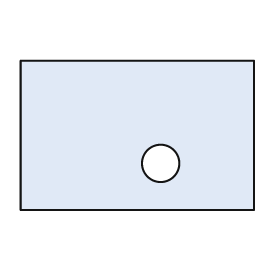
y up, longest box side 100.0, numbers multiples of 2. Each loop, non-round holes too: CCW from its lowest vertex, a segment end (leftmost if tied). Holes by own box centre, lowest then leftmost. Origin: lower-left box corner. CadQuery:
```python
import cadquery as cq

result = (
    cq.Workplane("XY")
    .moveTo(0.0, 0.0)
    .lineTo(100.0, 0.0)
    .lineTo(100.0, 64.0)
    .lineTo(0.0, 64.0)
    .close()
    .moveTo(60.0, 20.0)
    .circle(8.0)
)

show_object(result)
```